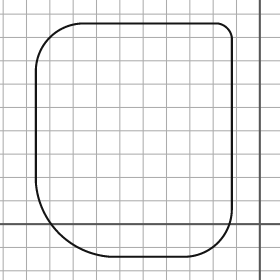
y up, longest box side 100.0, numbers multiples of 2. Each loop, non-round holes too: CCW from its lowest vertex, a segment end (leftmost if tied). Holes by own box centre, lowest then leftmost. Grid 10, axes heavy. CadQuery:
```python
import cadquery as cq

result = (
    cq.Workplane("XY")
    .moveTo(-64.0, -14.0)
    .lineTo(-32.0, -14.0)
    .threePointArc((-18.0, -8.0), (-12.0, 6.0))
    .lineTo(-12.0, 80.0)
    .threePointArc((-14.0, 84.0), (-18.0, 86.0))
    .lineTo(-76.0, 86.0)
    .threePointArc((-90.0, 80.0), (-96.0, 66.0))
    .lineTo(-96.0, 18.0)
    .threePointArc((-86.0, -4.0), (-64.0, -14.0))
    .close()
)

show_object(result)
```